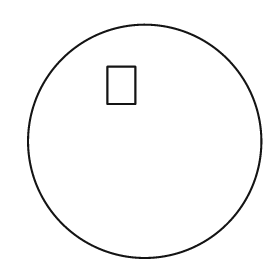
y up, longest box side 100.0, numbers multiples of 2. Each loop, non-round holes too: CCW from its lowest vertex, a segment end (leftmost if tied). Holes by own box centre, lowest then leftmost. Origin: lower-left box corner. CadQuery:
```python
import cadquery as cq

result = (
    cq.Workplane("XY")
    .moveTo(50.0, 50.0)
    .circle(50.0)
    .moveTo(34.0, 66.0)
    .lineTo(46.0, 66.0)
    .lineTo(46.0, 82.0)
    .lineTo(34.0, 82.0)
    .close()
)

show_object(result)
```